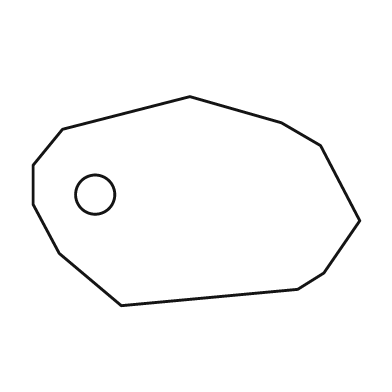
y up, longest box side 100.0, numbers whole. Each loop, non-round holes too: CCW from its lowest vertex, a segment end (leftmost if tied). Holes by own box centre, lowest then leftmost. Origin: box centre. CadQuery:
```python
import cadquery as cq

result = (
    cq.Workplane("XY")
    .moveTo(-23.0, -32.0)
    .lineTo(31.0, -27.0)
    .lineTo(39.0, -22.0)
    .lineTo(50.0, -6.0)
    .lineTo(38.0, 17.0)
    .lineTo(26.0, 24.0)
    .lineTo(-2.0, 32.0)
    .lineTo(-41.0, 22.0)
    .lineTo(-50.0, 11.0)
    .lineTo(-50.0, -1.0)
    .lineTo(-42.0, -16.0)
    .close()
    .moveTo(-31.0, 2.0)
    .circle(6.0)
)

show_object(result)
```